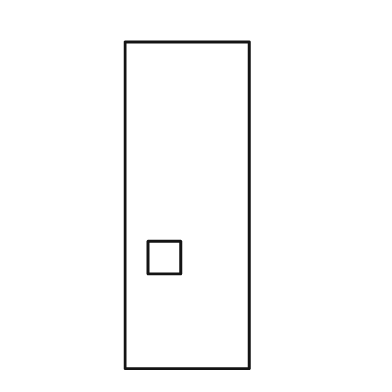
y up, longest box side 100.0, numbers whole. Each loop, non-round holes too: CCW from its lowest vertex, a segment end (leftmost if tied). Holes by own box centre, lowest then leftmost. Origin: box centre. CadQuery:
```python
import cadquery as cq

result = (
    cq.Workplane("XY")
    .moveTo(-19.0, -50.0)
    .lineTo(19.0, -50.0)
    .lineTo(19.0, 50.0)
    .lineTo(-19.0, 50.0)
    .close()
    .moveTo(-12.0, -21.0)
    .lineTo(-2.0, -21.0)
    .lineTo(-2.0, -11.0)
    .lineTo(-12.0, -11.0)
    .close()
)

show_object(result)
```